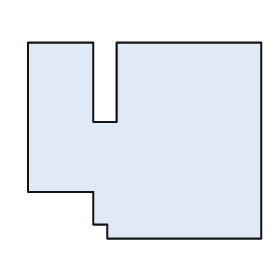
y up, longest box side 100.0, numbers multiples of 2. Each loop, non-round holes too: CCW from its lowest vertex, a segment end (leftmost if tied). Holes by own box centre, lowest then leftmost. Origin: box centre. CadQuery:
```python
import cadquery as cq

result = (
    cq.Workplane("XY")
    .moveTo(-16.0, -42.0)
    .lineTo(50.0, -42.0)
    .lineTo(50.0, 42.0)
    .lineTo(-12.0, 42.0)
    .lineTo(-12.0, 8.0)
    .lineTo(-22.0, 8.0)
    .lineTo(-22.0, 42.0)
    .lineTo(-50.0, 42.0)
    .lineTo(-50.0, -22.0)
    .lineTo(-22.0, -22.0)
    .lineTo(-22.0, -36.0)
    .lineTo(-16.0, -36.0)
    .close()
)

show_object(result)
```